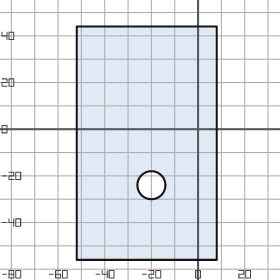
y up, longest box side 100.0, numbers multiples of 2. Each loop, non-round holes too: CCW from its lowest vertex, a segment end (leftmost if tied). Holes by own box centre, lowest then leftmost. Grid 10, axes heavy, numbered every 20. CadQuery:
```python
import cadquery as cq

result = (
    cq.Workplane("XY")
    .moveTo(-52.0, -56.0)
    .lineTo(8.0, -56.0)
    .lineTo(8.0, 44.0)
    .lineTo(-52.0, 44.0)
    .close()
    .moveTo(-20.0, -24.0)
    .circle(6.0)
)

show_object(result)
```